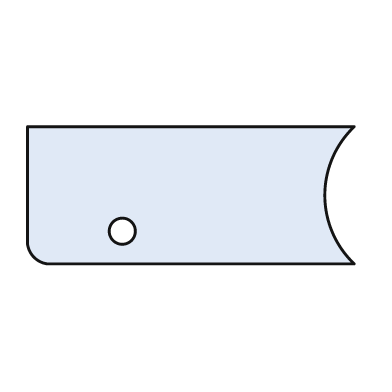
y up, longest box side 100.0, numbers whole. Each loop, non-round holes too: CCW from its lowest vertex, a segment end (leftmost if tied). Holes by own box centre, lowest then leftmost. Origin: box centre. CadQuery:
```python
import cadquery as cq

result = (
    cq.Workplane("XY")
    .moveTo(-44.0, -21.0)
    .lineTo(50.0, -21.0)
    .threePointArc((41.0, 0.0), (50.0, 21.0))
    .lineTo(-50.0, 21.0)
    .lineTo(-50.0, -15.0)
    .threePointArc((-48.0, -19.0), (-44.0, -21.0))
    .close()
    .moveTo(-21.0, -11.0)
    .circle(4.0)
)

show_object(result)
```